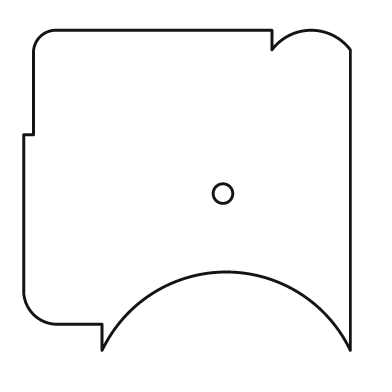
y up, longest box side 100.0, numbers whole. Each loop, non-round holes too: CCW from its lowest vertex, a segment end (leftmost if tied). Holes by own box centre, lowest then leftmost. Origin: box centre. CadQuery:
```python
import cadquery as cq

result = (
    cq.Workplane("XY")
    .moveTo(-26.0, -49.0)
    .threePointArc((12.0, -25.0), (50.0, -49.0))
    .lineTo(50.0, 43.0)
    .threePointArc((38.0, 49.0), (26.0, 43.0))
    .lineTo(26.0, 49.0)
    .lineTo(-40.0, 49.0)
    .threePointArc((-45.0, 47.0), (-47.0, 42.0))
    .lineTo(-47.0, 17.0)
    .lineTo(-50.0, 17.0)
    .lineTo(-50.0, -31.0)
    .threePointArc((-47.0, -38.0), (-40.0, -41.0))
    .lineTo(-26.0, -41.0)
    .close()
    .moveTo(11.0, -1.0)
    .circle(3.0)
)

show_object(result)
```